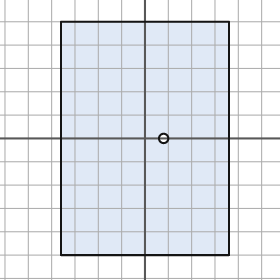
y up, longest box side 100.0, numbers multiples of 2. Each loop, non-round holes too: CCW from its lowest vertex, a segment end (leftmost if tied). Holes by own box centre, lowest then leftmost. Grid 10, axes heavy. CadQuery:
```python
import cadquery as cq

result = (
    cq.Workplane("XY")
    .moveTo(-36.0, -50.0)
    .lineTo(36.0, -50.0)
    .lineTo(36.0, 50.0)
    .lineTo(-36.0, 50.0)
    .close()
    .moveTo(8.0, 0.0)
    .circle(2.0)
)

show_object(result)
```